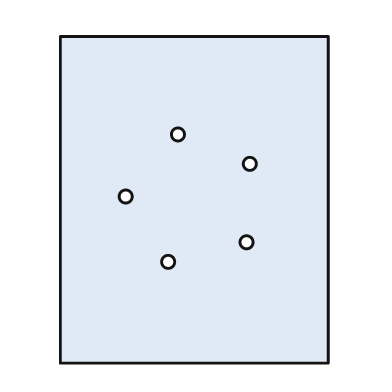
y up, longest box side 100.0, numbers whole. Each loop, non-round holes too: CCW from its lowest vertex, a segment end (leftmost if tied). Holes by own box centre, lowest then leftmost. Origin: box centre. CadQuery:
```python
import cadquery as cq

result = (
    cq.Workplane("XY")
    .moveTo(-41.0, -50.0)
    .lineTo(41.0, -50.0)
    .lineTo(41.0, 50.0)
    .lineTo(-41.0, 50.0)
    .close()
    .moveTo(-8.0, -19.0)
    .circle(2.0)
    .moveTo(16.0, -13.0)
    .circle(2.0)
    .moveTo(-21.0, 1.0)
    .circle(2.0)
    .moveTo(17.0, 11.0)
    .circle(2.0)
    .moveTo(-5.0, 20.0)
    .circle(2.0)
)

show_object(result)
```